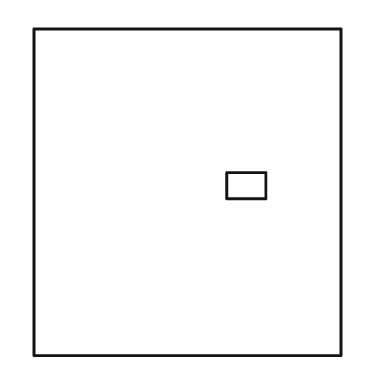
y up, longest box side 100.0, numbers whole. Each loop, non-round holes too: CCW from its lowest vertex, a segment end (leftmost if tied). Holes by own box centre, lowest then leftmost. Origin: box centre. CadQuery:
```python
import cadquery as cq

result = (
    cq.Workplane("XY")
    .moveTo(-47.0, -50.0)
    .lineTo(47.0, -50.0)
    .lineTo(47.0, 50.0)
    .lineTo(-47.0, 50.0)
    .close()
    .moveTo(12.0, -2.0)
    .lineTo(24.0, -2.0)
    .lineTo(24.0, 6.0)
    .lineTo(12.0, 6.0)
    .close()
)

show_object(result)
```